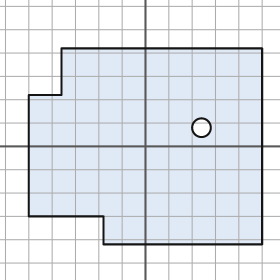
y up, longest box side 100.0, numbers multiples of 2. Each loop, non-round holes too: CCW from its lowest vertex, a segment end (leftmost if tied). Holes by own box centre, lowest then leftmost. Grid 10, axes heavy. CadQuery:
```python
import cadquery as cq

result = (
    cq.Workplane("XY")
    .moveTo(-18.0, -42.0)
    .lineTo(50.0, -42.0)
    .lineTo(50.0, 42.0)
    .lineTo(-36.0, 42.0)
    .lineTo(-36.0, 22.0)
    .lineTo(-50.0, 22.0)
    .lineTo(-50.0, -30.0)
    .lineTo(-18.0, -30.0)
    .close()
    .moveTo(24.0, 8.0)
    .circle(4.0)
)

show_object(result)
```